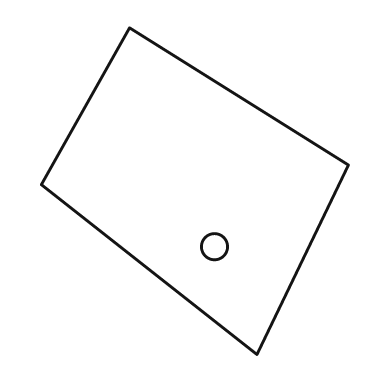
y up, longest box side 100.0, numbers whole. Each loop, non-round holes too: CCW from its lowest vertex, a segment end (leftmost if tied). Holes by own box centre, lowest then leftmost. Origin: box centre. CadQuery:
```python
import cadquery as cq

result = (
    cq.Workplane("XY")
    .moveTo(19.0, -50.0)
    .lineTo(47.0, 8.0)
    .lineTo(-20.0, 50.0)
    .lineTo(-47.0, 2.0)
    .close()
    .moveTo(6.0, -17.0)
    .circle(4.0)
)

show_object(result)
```